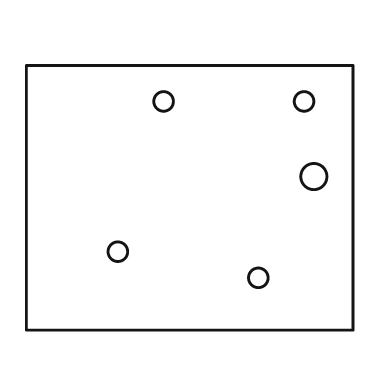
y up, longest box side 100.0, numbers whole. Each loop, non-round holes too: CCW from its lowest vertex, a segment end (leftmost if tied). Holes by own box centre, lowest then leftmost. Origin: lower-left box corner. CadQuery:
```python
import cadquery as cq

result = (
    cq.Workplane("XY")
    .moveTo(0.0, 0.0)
    .lineTo(100.0, 0.0)
    .lineTo(100.0, 81.0)
    .lineTo(0.0, 81.0)
    .close()
    .moveTo(71.0, 16.0)
    .circle(3.0)
    .moveTo(28.0, 24.0)
    .circle(3.0)
    .moveTo(88.0, 47.0)
    .circle(4.0)
    .moveTo(42.0, 70.0)
    .circle(3.0)
    .moveTo(85.0, 70.0)
    .circle(3.0)
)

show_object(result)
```